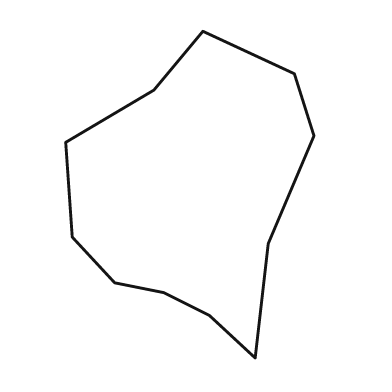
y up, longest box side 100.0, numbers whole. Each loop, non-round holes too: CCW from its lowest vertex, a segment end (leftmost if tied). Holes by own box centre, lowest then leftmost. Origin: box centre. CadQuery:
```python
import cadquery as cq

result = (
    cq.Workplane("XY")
    .moveTo(20.0, -50.0)
    .lineTo(24.0, -15.0)
    .lineTo(38.0, 18.0)
    .lineTo(32.0, 37.0)
    .lineTo(4.0, 50.0)
    .lineTo(-11.0, 32.0)
    .lineTo(-38.0, 16.0)
    .lineTo(-36.0, -13.0)
    .lineTo(-23.0, -27.0)
    .lineTo(-8.0, -30.0)
    .lineTo(6.0, -37.0)
    .close()
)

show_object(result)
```